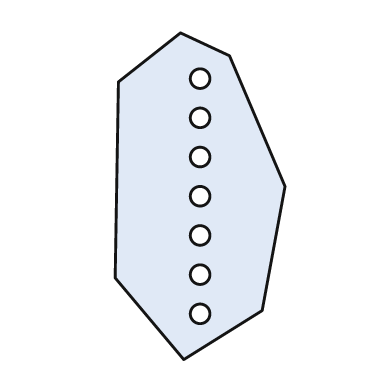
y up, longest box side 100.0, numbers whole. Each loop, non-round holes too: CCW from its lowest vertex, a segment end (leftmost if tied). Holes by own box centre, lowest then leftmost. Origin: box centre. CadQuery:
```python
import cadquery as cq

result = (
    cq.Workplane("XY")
    .moveTo(-5.0, -50.0)
    .lineTo(19.0, -35.0)
    .lineTo(26.0, 3.0)
    .lineTo(9.0, 43.0)
    .lineTo(-6.0, 50.0)
    .lineTo(-25.0, 35.0)
    .lineTo(-26.0, -25.0)
    .close()
    .moveTo(0.0, -36.0)
    .circle(3.0)
    .moveTo(0.0, -24.0)
    .circle(3.0)
    .moveTo(0.0, -12.0)
    .circle(3.0)
    .moveTo(0.0, 0.0)
    .circle(3.0)
    .moveTo(0.0, 12.0)
    .circle(3.0)
    .moveTo(0.0, 24.0)
    .circle(3.0)
    .moveTo(0.0, 36.0)
    .circle(3.0)
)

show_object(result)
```